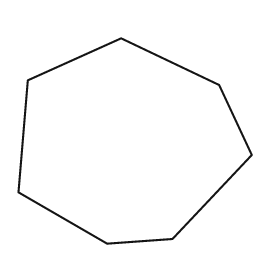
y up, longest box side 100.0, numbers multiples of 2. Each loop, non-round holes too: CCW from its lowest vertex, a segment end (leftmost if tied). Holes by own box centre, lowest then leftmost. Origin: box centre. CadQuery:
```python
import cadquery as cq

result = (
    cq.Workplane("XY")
    .moveTo(-12.0, -44.0)
    .lineTo(16.0, -42.0)
    .lineTo(50.0, -6.0)
    .lineTo(36.0, 24.0)
    .lineTo(-6.0, 44.0)
    .lineTo(-46.0, 26.0)
    .lineTo(-50.0, -22.0)
    .close()
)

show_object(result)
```